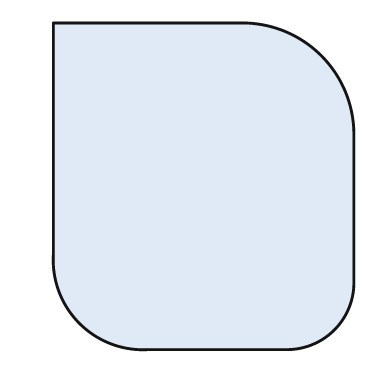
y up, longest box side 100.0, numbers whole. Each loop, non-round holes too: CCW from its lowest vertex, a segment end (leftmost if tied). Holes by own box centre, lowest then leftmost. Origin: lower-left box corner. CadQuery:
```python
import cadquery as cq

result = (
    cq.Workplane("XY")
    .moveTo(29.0, 0.0)
    .lineTo(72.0, 0.0)
    .threePointArc((86.0, 6.0), (92.0, 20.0))
    .lineTo(92.0, 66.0)
    .threePointArc((82.0, 90.0), (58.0, 100.0))
    .lineTo(0.0, 100.0)
    .lineTo(0.0, 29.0)
    .threePointArc((8.0, 8.0), (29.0, 0.0))
    .close()
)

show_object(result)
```